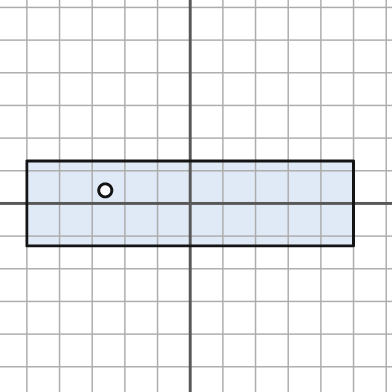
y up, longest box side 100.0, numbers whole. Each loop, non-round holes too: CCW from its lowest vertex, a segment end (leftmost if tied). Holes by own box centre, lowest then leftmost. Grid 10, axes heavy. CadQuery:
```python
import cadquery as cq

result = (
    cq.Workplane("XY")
    .moveTo(-50.0, -13.0)
    .lineTo(50.0, -13.0)
    .lineTo(50.0, 13.0)
    .lineTo(-50.0, 13.0)
    .close()
    .moveTo(-26.0, 4.0)
    .circle(2.0)
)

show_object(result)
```